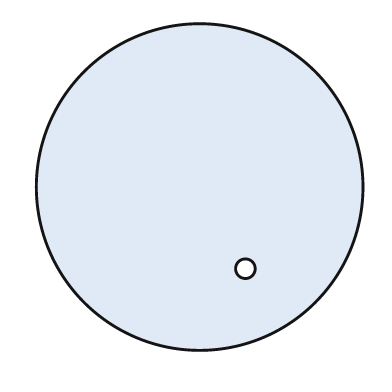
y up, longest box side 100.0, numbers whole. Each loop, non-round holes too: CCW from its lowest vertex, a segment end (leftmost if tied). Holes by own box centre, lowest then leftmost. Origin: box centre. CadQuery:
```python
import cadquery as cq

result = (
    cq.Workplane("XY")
    .moveTo(0.0, 0.0)
    .circle(50.0)
    .moveTo(14.0, -25.0)
    .circle(3.0)
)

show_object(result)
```